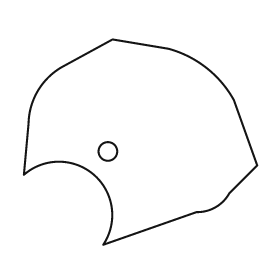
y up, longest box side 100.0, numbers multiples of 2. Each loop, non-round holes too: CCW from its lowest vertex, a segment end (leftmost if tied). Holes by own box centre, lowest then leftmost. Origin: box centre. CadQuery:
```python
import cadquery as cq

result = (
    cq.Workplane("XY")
    .moveTo(-16.0, -44.0)
    .lineTo(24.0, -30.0)
    .threePointArc((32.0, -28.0), (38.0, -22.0))
    .lineTo(50.0, -10.0)
    .lineTo(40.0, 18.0)
    .threePointArc((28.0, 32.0), (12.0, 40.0))
    .lineTo(-12.0, 44.0)
    .lineTo(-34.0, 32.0)
    .threePointArc((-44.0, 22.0), (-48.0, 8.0))
    .lineTo(-50.0, -14.0)
    .threePointArc((-20.0, -14.0), (-16.0, -44.0))
    .close()
    .moveTo(-14.0, -4.0)
    .circle(4.0)
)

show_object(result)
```